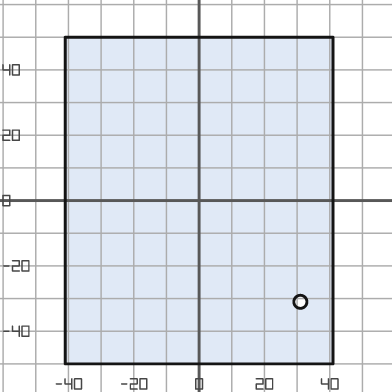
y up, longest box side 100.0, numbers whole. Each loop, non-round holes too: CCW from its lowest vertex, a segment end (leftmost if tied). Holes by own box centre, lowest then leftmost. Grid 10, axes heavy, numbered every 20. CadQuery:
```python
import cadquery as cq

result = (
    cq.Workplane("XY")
    .moveTo(-41.0, -50.0)
    .lineTo(41.0, -50.0)
    .lineTo(41.0, 50.0)
    .lineTo(-41.0, 50.0)
    .close()
    .moveTo(31.0, -31.0)
    .circle(2.0)
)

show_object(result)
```